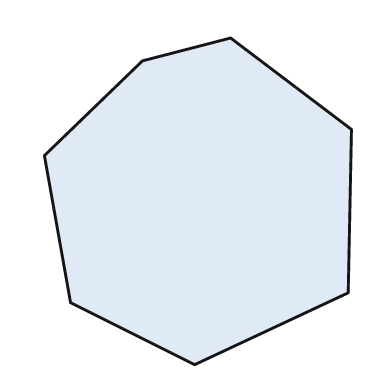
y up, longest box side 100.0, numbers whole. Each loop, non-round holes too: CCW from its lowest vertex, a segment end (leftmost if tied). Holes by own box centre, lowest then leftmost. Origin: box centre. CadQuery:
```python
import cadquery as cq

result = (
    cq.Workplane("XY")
    .moveTo(-1.0, -50.0)
    .lineTo(46.0, -28.0)
    .lineTo(47.0, 22.0)
    .lineTo(10.0, 50.0)
    .lineTo(-17.0, 43.0)
    .lineTo(-47.0, 14.0)
    .lineTo(-39.0, -31.0)
    .close()
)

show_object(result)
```